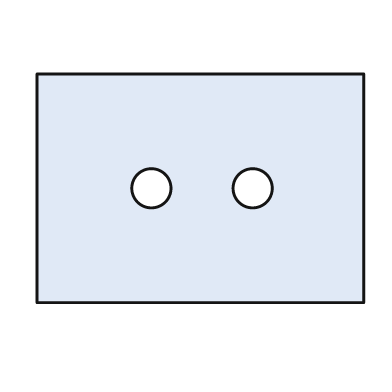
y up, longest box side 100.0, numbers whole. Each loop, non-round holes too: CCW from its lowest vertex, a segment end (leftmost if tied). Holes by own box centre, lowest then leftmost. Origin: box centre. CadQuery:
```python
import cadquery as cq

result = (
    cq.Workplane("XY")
    .moveTo(-50.0, -35.0)
    .lineTo(50.0, -35.0)
    .lineTo(50.0, 35.0)
    .lineTo(-50.0, 35.0)
    .close()
    .moveTo(-15.0, 0.0)
    .circle(6.0)
    .moveTo(16.0, 0.0)
    .circle(6.0)
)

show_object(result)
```